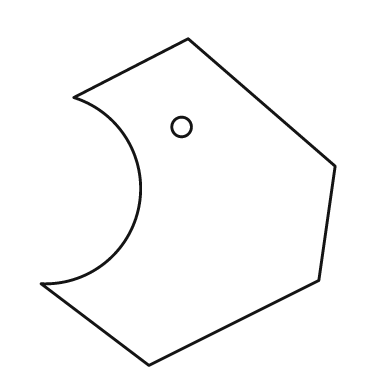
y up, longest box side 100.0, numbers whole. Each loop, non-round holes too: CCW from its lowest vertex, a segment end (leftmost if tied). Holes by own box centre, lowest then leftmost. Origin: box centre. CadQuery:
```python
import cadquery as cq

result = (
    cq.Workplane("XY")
    .moveTo(-12.0, -50.0)
    .lineTo(40.0, -24.0)
    .lineTo(45.0, 11.0)
    .lineTo(0.0, 50.0)
    .lineTo(-35.0, 32.0)
    .threePointArc((-15.0, -1.0), (-45.0, -25.0))
    .close()
    .moveTo(-2.0, 23.0)
    .circle(3.0)
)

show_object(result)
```